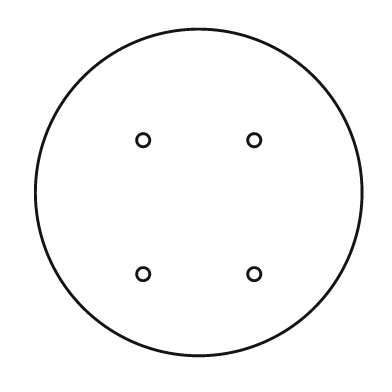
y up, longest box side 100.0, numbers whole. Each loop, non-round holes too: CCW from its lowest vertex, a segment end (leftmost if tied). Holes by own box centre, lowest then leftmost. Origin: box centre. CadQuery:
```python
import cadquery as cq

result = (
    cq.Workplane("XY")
    .moveTo(0.0, 0.0)
    .circle(50.0)
    .moveTo(-17.0, -25.0)
    .circle(2.0)
    .moveTo(17.0, -25.0)
    .circle(2.0)
    .moveTo(-17.0, 16.0)
    .circle(2.0)
    .moveTo(17.0, 16.0)
    .circle(2.0)
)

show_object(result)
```